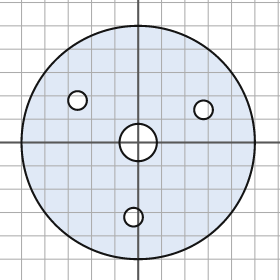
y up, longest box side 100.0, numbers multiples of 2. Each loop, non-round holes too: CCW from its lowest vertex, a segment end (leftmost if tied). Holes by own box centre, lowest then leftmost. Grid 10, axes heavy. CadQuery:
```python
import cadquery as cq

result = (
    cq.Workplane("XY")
    .moveTo(0.0, 0.0)
    .circle(50.0)
    .moveTo(-2.0, -32.0)
    .circle(4.0)
    .moveTo(0.0, 0.0)
    .circle(8.0)
    .moveTo(28.0, 14.0)
    .circle(4.0)
    .moveTo(-26.0, 18.0)
    .circle(4.0)
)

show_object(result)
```